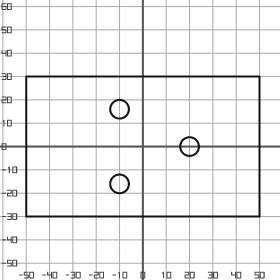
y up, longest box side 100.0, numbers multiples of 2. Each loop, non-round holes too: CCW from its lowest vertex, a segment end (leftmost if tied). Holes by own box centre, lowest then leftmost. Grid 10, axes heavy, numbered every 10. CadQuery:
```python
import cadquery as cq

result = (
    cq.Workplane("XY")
    .moveTo(-50.0, -30.0)
    .lineTo(50.0, -30.0)
    .lineTo(50.0, 30.0)
    .lineTo(-50.0, 30.0)
    .close()
    .moveTo(-10.0, -16.0)
    .circle(4.0)
    .moveTo(20.0, 0.0)
    .circle(4.0)
    .moveTo(-10.0, 16.0)
    .circle(4.0)
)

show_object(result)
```